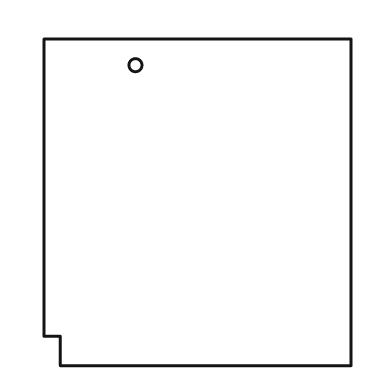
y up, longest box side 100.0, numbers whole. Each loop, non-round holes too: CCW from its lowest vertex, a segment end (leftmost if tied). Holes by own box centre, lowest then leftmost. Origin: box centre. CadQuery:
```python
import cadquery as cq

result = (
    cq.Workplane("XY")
    .moveTo(-42.0, -50.0)
    .lineTo(47.0, -50.0)
    .lineTo(47.0, 50.0)
    .lineTo(-47.0, 50.0)
    .lineTo(-47.0, -41.0)
    .lineTo(-42.0, -41.0)
    .close()
    .moveTo(-19.0, 42.0)
    .circle(2.0)
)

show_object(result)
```